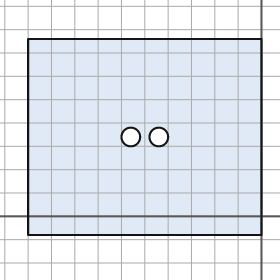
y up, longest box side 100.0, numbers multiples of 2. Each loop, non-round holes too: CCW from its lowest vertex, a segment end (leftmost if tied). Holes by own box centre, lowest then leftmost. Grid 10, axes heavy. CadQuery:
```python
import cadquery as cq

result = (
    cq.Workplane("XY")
    .moveTo(-100.0, -8.0)
    .lineTo(0.0, -8.0)
    .lineTo(0.0, 76.0)
    .lineTo(-100.0, 76.0)
    .close()
    .moveTo(-56.0, 34.0)
    .circle(4.0)
    .moveTo(-44.0, 34.0)
    .circle(4.0)
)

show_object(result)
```